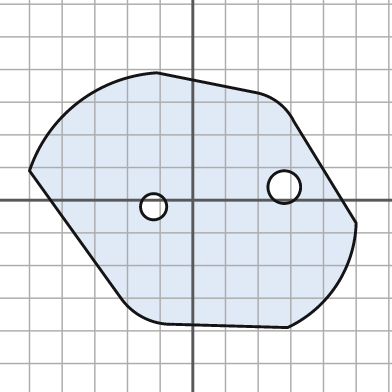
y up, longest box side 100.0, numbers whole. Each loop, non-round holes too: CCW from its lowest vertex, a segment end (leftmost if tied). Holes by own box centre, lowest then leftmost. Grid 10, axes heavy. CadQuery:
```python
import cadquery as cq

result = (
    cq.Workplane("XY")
    .moveTo(29.0, -39.0)
    .threePointArc((44.0, -26.0), (50.0, -7.0))
    .lineTo(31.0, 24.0)
    .threePointArc((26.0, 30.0), (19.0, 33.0))
    .lineTo(-11.0, 39.0)
    .threePointArc((-35.0, 30.0), (-50.0, 9.0))
    .lineTo(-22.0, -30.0)
    .threePointArc((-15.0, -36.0), (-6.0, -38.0))
    .close()
    .moveTo(-12.0, -2.0)
    .circle(4.0)
    .moveTo(28.0, 4.0)
    .circle(5.0)
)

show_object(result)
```